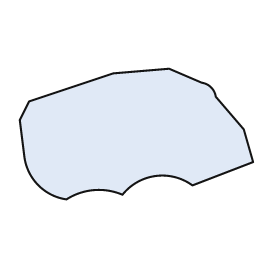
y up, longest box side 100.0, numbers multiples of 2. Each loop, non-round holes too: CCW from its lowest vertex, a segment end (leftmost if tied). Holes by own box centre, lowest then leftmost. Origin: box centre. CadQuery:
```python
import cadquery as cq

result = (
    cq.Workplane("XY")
    .moveTo(-30.0, -28.0)
    .threePointArc((-18.0, -24.0), (-6.0, -26.0))
    .threePointArc((8.0, -18.0), (24.0, -22.0))
    .lineTo(50.0, -12.0)
    .lineTo(46.0, 2.0)
    .lineTo(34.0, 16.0)
    .threePointArc((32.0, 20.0), (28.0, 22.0))
    .lineTo(14.0, 28.0)
    .lineTo(-10.0, 26.0)
    .lineTo(-46.0, 14.0)
    .lineTo(-50.0, 6.0)
    .lineTo(-48.0, -10.0)
    .threePointArc((-42.0, -22.0), (-30.0, -28.0))
    .close()
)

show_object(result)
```